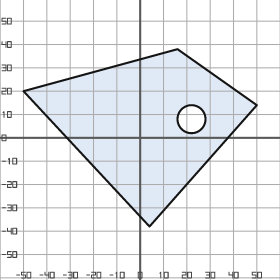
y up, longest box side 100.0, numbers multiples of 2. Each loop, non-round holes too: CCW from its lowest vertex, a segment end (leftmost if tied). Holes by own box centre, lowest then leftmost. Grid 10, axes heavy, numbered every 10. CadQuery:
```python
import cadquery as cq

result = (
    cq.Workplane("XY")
    .moveTo(4.0, -38.0)
    .lineTo(50.0, 14.0)
    .lineTo(16.0, 38.0)
    .lineTo(-50.0, 20.0)
    .close()
    .moveTo(22.0, 8.0)
    .circle(6.0)
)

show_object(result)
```